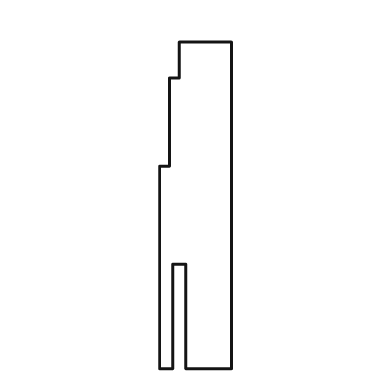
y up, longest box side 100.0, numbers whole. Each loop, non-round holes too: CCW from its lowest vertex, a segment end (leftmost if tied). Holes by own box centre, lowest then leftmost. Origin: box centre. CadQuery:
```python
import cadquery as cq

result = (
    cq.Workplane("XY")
    .moveTo(-11.0, -50.0)
    .lineTo(-7.0, -50.0)
    .lineTo(-7.0, -18.0)
    .lineTo(-3.0, -18.0)
    .lineTo(-3.0, -50.0)
    .lineTo(11.0, -50.0)
    .lineTo(11.0, 50.0)
    .lineTo(-5.0, 50.0)
    .lineTo(-5.0, 39.0)
    .lineTo(-8.0, 39.0)
    .lineTo(-8.0, 12.0)
    .lineTo(-11.0, 12.0)
    .close()
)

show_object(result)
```